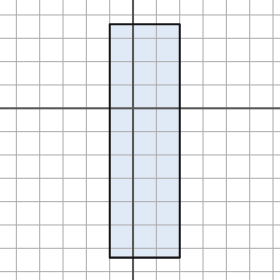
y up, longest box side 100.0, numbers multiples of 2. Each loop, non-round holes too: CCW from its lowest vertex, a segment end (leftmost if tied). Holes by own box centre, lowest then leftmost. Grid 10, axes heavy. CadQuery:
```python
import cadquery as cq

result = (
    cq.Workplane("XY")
    .moveTo(-10.0, -64.0)
    .lineTo(20.0, -64.0)
    .lineTo(20.0, 36.0)
    .lineTo(-10.0, 36.0)
    .close()
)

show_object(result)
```